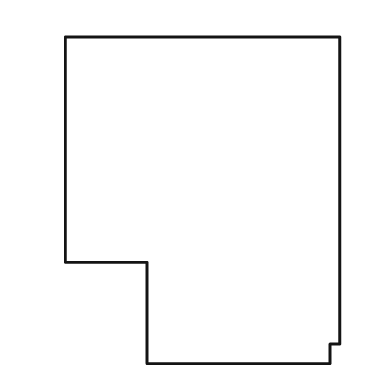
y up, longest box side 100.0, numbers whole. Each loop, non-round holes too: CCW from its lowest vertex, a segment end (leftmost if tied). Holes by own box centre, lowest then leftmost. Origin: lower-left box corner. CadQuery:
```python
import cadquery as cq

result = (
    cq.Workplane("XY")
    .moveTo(25.0, 0.0)
    .lineTo(81.0, 0.0)
    .lineTo(81.0, 6.0)
    .lineTo(84.0, 6.0)
    .lineTo(84.0, 100.0)
    .lineTo(0.0, 100.0)
    .lineTo(0.0, 31.0)
    .lineTo(25.0, 31.0)
    .close()
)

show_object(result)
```